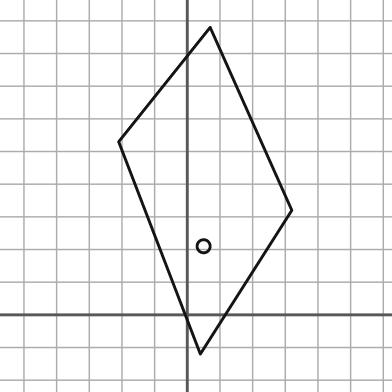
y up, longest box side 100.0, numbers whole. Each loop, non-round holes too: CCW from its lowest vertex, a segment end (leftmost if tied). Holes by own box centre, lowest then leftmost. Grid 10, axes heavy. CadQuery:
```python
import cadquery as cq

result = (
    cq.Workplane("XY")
    .moveTo(4.0, -12.0)
    .lineTo(32.0, 32.0)
    .lineTo(7.0, 88.0)
    .lineTo(-21.0, 53.0)
    .close()
    .moveTo(5.0, 21.0)
    .circle(2.0)
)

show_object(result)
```